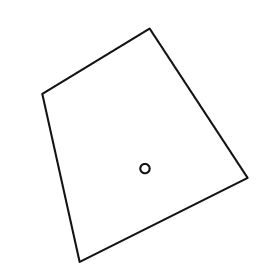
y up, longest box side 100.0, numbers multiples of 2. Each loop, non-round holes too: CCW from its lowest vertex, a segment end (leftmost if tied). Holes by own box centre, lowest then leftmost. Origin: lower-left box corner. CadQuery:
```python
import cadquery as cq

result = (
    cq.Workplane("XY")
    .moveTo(16.0, 0.0)
    .lineTo(88.0, 36.0)
    .lineTo(46.0, 100.0)
    .lineTo(0.0, 72.0)
    .close()
    .moveTo(44.0, 40.0)
    .circle(2.0)
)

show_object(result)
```